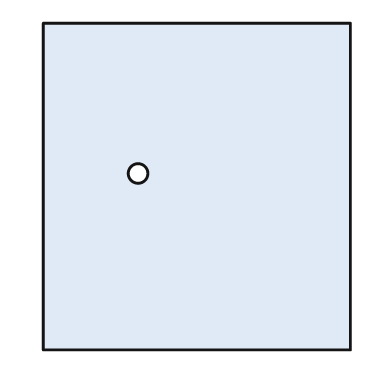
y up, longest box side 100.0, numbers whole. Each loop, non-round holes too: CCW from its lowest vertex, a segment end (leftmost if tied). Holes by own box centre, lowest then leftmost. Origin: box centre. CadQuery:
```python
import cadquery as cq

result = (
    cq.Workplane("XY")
    .moveTo(-47.0, -50.0)
    .lineTo(47.0, -50.0)
    .lineTo(47.0, 50.0)
    .lineTo(-47.0, 50.0)
    .close()
    .moveTo(-18.0, 4.0)
    .circle(3.0)
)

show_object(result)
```